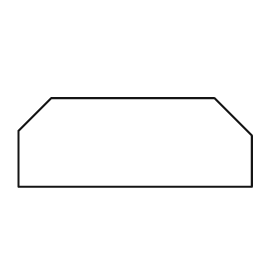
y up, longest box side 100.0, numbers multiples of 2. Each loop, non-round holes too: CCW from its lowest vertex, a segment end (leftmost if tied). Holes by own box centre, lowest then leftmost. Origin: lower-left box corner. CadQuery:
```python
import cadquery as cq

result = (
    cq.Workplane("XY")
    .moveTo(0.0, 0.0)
    .lineTo(100.0, 0.0)
    .lineTo(100.0, 22.0)
    .lineTo(84.0, 38.0)
    .lineTo(14.0, 38.0)
    .lineTo(0.0, 24.0)
    .close()
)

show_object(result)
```